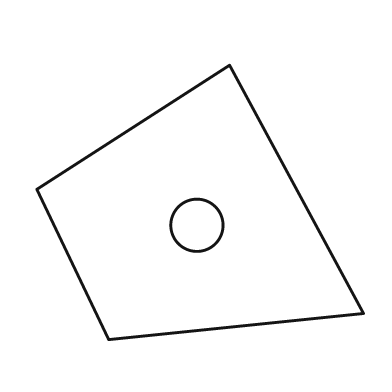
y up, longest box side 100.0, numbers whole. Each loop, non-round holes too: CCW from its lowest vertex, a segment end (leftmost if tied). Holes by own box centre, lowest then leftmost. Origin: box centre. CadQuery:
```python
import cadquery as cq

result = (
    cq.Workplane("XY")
    .moveTo(-28.0, -42.0)
    .lineTo(50.0, -34.0)
    .lineTo(9.0, 42.0)
    .lineTo(-50.0, 4.0)
    .close()
    .moveTo(-1.0, -7.0)
    .circle(8.0)
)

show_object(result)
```